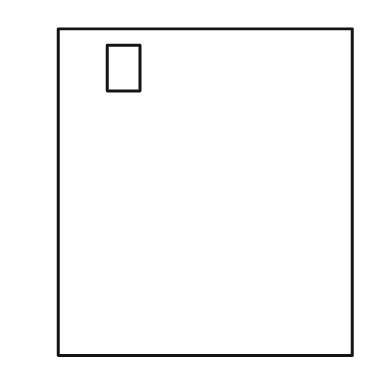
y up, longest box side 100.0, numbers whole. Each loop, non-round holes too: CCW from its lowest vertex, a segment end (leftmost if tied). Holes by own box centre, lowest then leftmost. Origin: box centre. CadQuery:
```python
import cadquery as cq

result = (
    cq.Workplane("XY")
    .moveTo(-45.0, -50.0)
    .lineTo(45.0, -50.0)
    .lineTo(45.0, 50.0)
    .lineTo(-45.0, 50.0)
    .close()
    .moveTo(-30.0, 31.0)
    .lineTo(-20.0, 31.0)
    .lineTo(-20.0, 45.0)
    .lineTo(-30.0, 45.0)
    .close()
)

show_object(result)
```